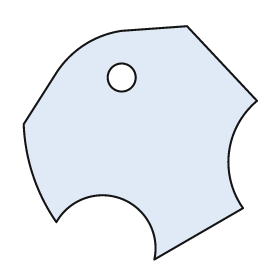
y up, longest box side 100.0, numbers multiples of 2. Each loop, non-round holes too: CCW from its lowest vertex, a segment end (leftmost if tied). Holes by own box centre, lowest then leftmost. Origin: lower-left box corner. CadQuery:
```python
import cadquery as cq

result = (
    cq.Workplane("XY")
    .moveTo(56.0, 0.0)
    .lineTo(94.0, 22.0)
    .threePointArc((88.0, 46.0), (100.0, 68.0))
    .lineTo(70.0, 100.0)
    .lineTo(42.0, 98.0)
    .threePointArc((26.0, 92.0), (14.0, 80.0))
    .lineTo(0.0, 58.0)
    .threePointArc((4.0, 36.0), (14.0, 16.0))
    .threePointArc((42.0, 26.0), (56.0, 0.0))
    .close()
    .moveTo(42.0, 78.0)
    .circle(6.0)
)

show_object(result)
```